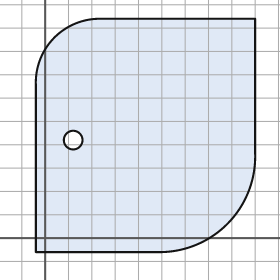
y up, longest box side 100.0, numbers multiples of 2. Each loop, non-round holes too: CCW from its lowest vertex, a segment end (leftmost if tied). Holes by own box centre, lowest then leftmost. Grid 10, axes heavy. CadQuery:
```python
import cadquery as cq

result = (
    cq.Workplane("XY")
    .moveTo(-4.0, -6.0)
    .lineTo(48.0, -6.0)
    .threePointArc((78.0, 6.0), (90.0, 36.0))
    .lineTo(90.0, 94.0)
    .lineTo(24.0, 94.0)
    .threePointArc((4.0, 86.0), (-4.0, 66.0))
    .close()
    .moveTo(12.0, 42.0)
    .circle(4.0)
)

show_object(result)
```